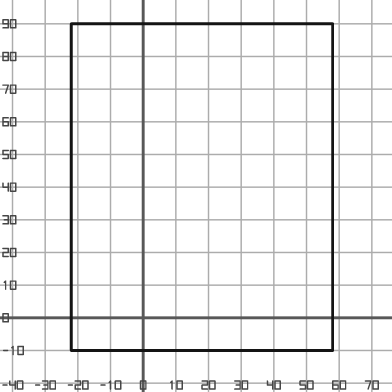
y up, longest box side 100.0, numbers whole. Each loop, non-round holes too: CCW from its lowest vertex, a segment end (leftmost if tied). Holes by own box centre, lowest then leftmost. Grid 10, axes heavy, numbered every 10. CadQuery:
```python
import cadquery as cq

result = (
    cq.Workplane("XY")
    .moveTo(-22.0, -10.0)
    .lineTo(58.0, -10.0)
    .lineTo(58.0, 90.0)
    .lineTo(-22.0, 90.0)
    .close()
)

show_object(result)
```